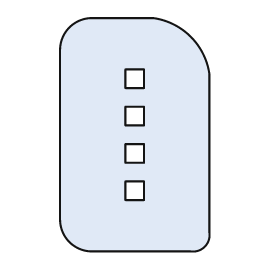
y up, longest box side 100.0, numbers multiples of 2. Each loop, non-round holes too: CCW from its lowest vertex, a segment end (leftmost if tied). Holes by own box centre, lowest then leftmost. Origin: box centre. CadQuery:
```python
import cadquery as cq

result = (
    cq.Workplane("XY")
    .moveTo(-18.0, -50.0)
    .lineTo(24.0, -50.0)
    .threePointArc((30.0, -48.0), (32.0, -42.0))
    .lineTo(32.0, 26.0)
    .threePointArc((24.0, 42.0), (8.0, 50.0))
    .lineTo(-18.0, 50.0)
    .threePointArc((-28.0, 46.0), (-32.0, 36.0))
    .lineTo(-32.0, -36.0)
    .threePointArc((-28.0, -46.0), (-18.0, -50.0))
    .close()
    .moveTo(-4.0, -28.0)
    .lineTo(4.0, -28.0)
    .lineTo(4.0, -20.0)
    .lineTo(-4.0, -20.0)
    .close()
    .moveTo(-4.0, -12.0)
    .lineTo(4.0, -12.0)
    .lineTo(4.0, -4.0)
    .lineTo(-4.0, -4.0)
    .close()
    .moveTo(-4.0, 4.0)
    .lineTo(4.0, 4.0)
    .lineTo(4.0, 12.0)
    .lineTo(-4.0, 12.0)
    .close()
    .moveTo(-4.0, 20.0)
    .lineTo(4.0, 20.0)
    .lineTo(4.0, 28.0)
    .lineTo(-4.0, 28.0)
    .close()
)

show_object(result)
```